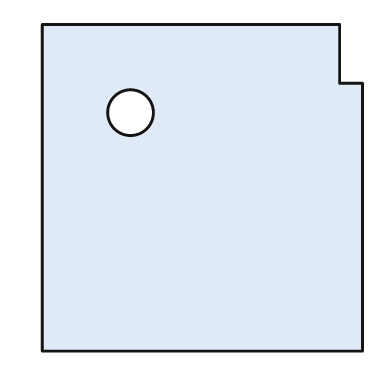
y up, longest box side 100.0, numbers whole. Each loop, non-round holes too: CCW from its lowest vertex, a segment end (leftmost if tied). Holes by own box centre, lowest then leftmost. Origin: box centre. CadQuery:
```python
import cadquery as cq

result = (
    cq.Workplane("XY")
    .moveTo(-49.0, -50.0)
    .lineTo(49.0, -50.0)
    .lineTo(49.0, 32.0)
    .lineTo(42.0, 32.0)
    .lineTo(42.0, 50.0)
    .lineTo(-49.0, 50.0)
    .close()
    .moveTo(-22.0, 23.0)
    .circle(7.0)
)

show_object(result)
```